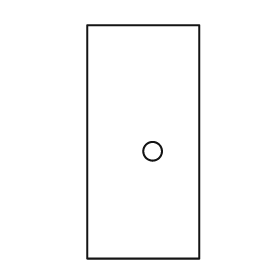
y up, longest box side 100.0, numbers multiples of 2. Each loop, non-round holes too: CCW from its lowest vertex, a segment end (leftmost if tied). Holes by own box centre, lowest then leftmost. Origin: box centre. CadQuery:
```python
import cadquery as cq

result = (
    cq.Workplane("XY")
    .moveTo(-24.0, -50.0)
    .lineTo(24.0, -50.0)
    .lineTo(24.0, 50.0)
    .lineTo(-24.0, 50.0)
    .close()
    .moveTo(4.0, -4.0)
    .circle(4.0)
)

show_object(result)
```